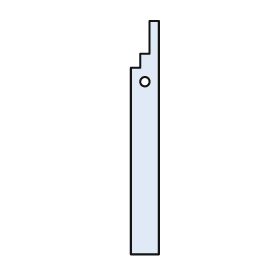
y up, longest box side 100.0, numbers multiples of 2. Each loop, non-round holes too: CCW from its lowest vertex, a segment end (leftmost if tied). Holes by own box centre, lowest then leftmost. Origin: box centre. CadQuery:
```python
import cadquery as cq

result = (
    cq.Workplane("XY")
    .moveTo(-6.0, -50.0)
    .lineTo(6.0, -50.0)
    .lineTo(6.0, 50.0)
    .lineTo(2.0, 50.0)
    .lineTo(2.0, 36.0)
    .lineTo(-2.0, 36.0)
    .lineTo(-2.0, 30.0)
    .lineTo(-6.0, 30.0)
    .close()
    .moveTo(0.0, 24.0)
    .circle(2.0)
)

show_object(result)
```